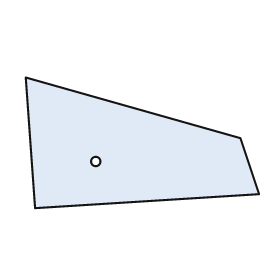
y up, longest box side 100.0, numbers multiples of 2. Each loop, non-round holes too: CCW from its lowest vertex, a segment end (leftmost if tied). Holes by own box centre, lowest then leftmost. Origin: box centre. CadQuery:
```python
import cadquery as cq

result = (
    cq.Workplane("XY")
    .moveTo(-46.0, -28.0)
    .lineTo(50.0, -22.0)
    .lineTo(42.0, 2.0)
    .lineTo(-50.0, 28.0)
    .close()
    .moveTo(-20.0, -8.0)
    .circle(2.0)
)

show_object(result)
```